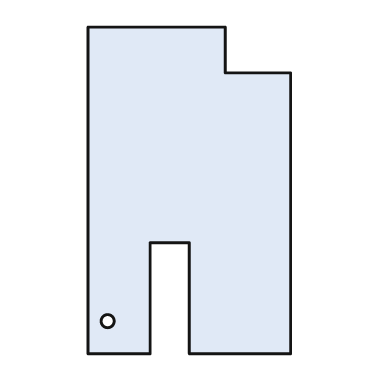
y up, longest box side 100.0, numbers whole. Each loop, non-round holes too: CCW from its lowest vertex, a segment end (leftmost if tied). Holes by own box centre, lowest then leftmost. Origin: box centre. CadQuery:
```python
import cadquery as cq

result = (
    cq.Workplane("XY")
    .moveTo(-31.0, -50.0)
    .lineTo(-12.0, -50.0)
    .lineTo(-12.0, -16.0)
    .lineTo(0.0, -16.0)
    .lineTo(0.0, -50.0)
    .lineTo(31.0, -50.0)
    .lineTo(31.0, 36.0)
    .lineTo(11.0, 36.0)
    .lineTo(11.0, 50.0)
    .lineTo(-31.0, 50.0)
    .close()
    .moveTo(-25.0, -40.0)
    .circle(2.0)
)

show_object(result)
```